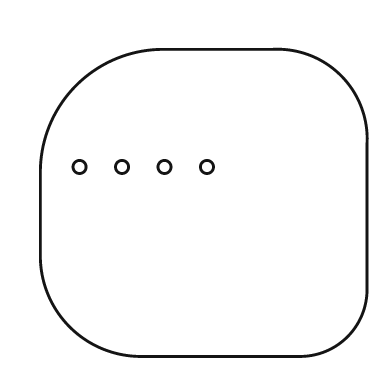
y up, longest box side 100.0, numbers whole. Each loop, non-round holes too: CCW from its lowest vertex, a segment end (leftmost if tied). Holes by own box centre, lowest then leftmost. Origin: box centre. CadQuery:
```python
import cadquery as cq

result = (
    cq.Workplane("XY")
    .moveTo(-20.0, -47.0)
    .lineTo(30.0, -47.0)
    .threePointArc((44.0, -41.0), (50.0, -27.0))
    .lineTo(50.0, 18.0)
    .threePointArc((42.0, 39.0), (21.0, 47.0))
    .lineTo(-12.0, 47.0)
    .threePointArc((-39.0, 36.0), (-50.0, 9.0))
    .lineTo(-50.0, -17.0)
    .threePointArc((-41.0, -38.0), (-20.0, -47.0))
    .close()
    .moveTo(-38.0, 11.0)
    .circle(2.0)
    .moveTo(-25.0, 11.0)
    .circle(2.0)
    .moveTo(-12.0, 11.0)
    .circle(2.0)
    .moveTo(1.0, 11.0)
    .circle(2.0)
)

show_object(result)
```